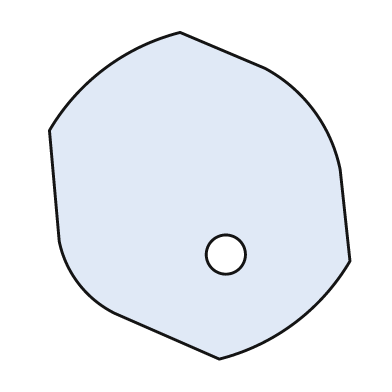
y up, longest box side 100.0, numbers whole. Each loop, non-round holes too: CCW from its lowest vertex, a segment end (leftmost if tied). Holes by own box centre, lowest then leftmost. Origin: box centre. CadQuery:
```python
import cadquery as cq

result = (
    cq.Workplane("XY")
    .moveTo(6.0, -50.0)
    .threePointArc((29.0, -39.0), (46.0, -20.0))
    .lineTo(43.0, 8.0)
    .threePointArc((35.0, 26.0), (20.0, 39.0))
    .lineTo(-6.0, 50.0)
    .threePointArc((-29.0, 39.0), (-46.0, 20.0))
    .lineTo(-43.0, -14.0)
    .threePointArc((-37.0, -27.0), (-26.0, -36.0))
    .close()
    .moveTo(8.0, -18.0)
    .circle(6.0)
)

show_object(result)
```